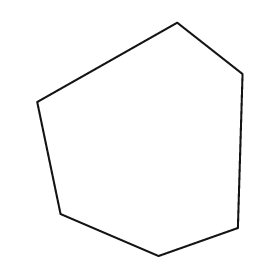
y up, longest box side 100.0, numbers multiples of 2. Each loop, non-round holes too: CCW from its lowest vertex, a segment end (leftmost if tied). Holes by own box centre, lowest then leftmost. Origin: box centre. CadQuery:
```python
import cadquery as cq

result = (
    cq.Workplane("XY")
    .moveTo(8.0, -50.0)
    .lineTo(42.0, -38.0)
    .lineTo(44.0, 28.0)
    .lineTo(16.0, 50.0)
    .lineTo(-44.0, 16.0)
    .lineTo(-34.0, -32.0)
    .close()
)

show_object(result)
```